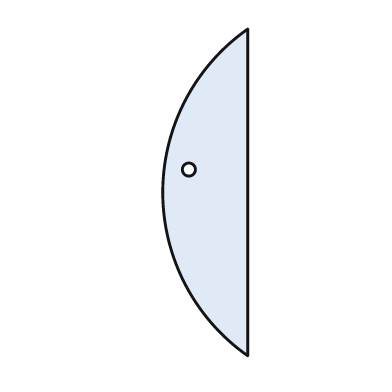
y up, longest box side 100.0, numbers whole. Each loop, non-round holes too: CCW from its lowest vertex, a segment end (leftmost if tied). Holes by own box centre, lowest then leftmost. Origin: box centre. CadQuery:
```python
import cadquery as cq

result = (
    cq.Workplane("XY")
    .moveTo(13.0, -50.0)
    .lineTo(13.0, 50.0)
    .threePointArc((-13.0, 0.0), (13.0, -50.0))
    .close()
    .moveTo(-5.0, 7.0)
    .circle(2.0)
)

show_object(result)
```